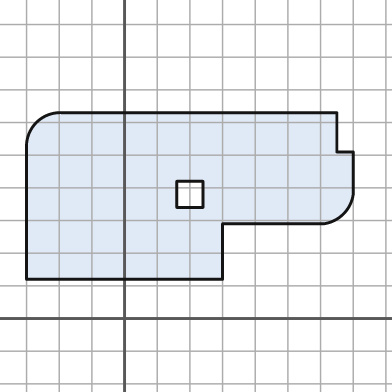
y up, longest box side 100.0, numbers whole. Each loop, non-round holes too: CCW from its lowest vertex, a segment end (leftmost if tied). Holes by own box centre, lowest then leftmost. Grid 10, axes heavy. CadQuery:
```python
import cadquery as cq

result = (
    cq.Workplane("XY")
    .moveTo(-30.0, 12.0)
    .lineTo(30.0, 12.0)
    .lineTo(30.0, 29.0)
    .lineTo(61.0, 29.0)
    .threePointArc((67.0, 32.0), (70.0, 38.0))
    .lineTo(70.0, 51.0)
    .lineTo(65.0, 51.0)
    .lineTo(65.0, 63.0)
    .lineTo(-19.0, 63.0)
    .threePointArc((-27.0, 60.0), (-30.0, 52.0))
    .close()
    .moveTo(16.0, 34.0)
    .lineTo(24.0, 34.0)
    .lineTo(24.0, 42.0)
    .lineTo(16.0, 42.0)
    .close()
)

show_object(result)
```